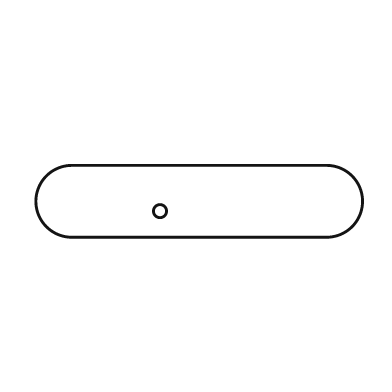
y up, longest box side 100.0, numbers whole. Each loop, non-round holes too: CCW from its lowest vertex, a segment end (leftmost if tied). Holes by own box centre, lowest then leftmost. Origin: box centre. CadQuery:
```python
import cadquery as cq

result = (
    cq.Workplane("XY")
    .moveTo(-39.0, -11.0)
    .lineTo(39.0, -11.0)
    .threePointArc((50.0, 0.0), (39.0, 11.0))
    .lineTo(-39.0, 11.0)
    .threePointArc((-50.0, 0.0), (-39.0, -11.0))
    .close()
    .moveTo(-12.0, -3.0)
    .circle(2.0)
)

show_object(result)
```